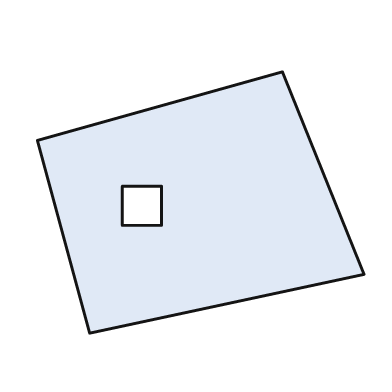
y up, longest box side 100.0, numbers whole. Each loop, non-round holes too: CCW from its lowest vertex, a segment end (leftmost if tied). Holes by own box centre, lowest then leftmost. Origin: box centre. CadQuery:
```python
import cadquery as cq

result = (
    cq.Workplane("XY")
    .moveTo(-34.0, -40.0)
    .lineTo(50.0, -22.0)
    .lineTo(25.0, 40.0)
    .lineTo(-50.0, 19.0)
    .close()
    .moveTo(-24.0, -7.0)
    .lineTo(-12.0, -7.0)
    .lineTo(-12.0, 5.0)
    .lineTo(-24.0, 5.0)
    .close()
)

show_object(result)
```